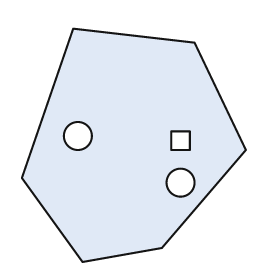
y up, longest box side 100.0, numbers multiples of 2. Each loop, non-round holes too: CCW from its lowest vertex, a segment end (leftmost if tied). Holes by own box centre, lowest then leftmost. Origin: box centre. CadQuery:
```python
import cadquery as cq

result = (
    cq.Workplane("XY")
    .moveTo(-22.0, -50.0)
    .lineTo(12.0, -44.0)
    .lineTo(48.0, -2.0)
    .lineTo(26.0, 44.0)
    .lineTo(-26.0, 50.0)
    .lineTo(-48.0, -14.0)
    .close()
    .moveTo(20.0, -16.0)
    .circle(6.0)
    .moveTo(16.0, -2.0)
    .lineTo(24.0, -2.0)
    .lineTo(24.0, 6.0)
    .lineTo(16.0, 6.0)
    .close()
    .moveTo(-24.0, 4.0)
    .circle(6.0)
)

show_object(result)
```